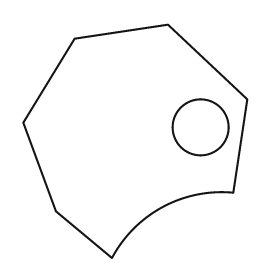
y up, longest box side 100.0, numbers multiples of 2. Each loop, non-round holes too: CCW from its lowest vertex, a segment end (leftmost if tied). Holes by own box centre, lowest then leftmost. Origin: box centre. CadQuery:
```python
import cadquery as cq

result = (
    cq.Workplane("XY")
    .moveTo(-10.0, -50.0)
    .threePointArc((12.0, -28.0), (42.0, -22.0))
    .lineTo(48.0, 18.0)
    .lineTo(14.0, 50.0)
    .lineTo(-26.0, 44.0)
    .lineTo(-48.0, 8.0)
    .lineTo(-34.0, -30.0)
    .close()
    .moveTo(28.0, 6.0)
    .circle(12.0)
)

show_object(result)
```